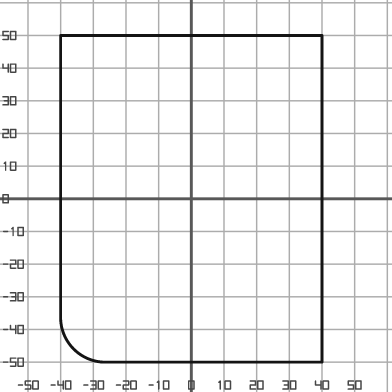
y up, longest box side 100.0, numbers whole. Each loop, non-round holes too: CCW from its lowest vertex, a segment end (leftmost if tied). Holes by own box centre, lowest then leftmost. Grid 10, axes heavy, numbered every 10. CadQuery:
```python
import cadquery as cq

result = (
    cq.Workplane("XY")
    .moveTo(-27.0, -50.0)
    .lineTo(40.0, -50.0)
    .lineTo(40.0, 50.0)
    .lineTo(-40.0, 50.0)
    .lineTo(-40.0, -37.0)
    .threePointArc((-36.0, -46.0), (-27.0, -50.0))
    .close()
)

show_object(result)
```